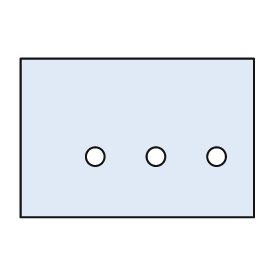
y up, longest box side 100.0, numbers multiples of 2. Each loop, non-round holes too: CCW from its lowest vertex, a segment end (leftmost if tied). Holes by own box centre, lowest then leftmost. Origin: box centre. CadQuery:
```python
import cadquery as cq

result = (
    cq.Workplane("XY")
    .moveTo(-50.0, -34.0)
    .lineTo(50.0, -34.0)
    .lineTo(50.0, 34.0)
    .lineTo(-50.0, 34.0)
    .close()
    .moveTo(-18.0, -8.0)
    .circle(4.0)
    .moveTo(8.0, -8.0)
    .circle(4.0)
    .moveTo(34.0, -8.0)
    .circle(4.0)
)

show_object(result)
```